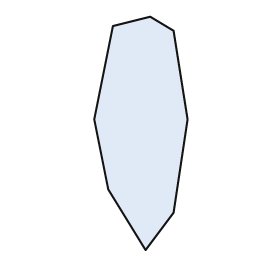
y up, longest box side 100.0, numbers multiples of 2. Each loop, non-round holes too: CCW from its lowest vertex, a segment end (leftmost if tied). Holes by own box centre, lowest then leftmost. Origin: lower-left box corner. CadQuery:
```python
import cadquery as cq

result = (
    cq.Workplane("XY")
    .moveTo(22.0, 0.0)
    .lineTo(34.0, 16.0)
    .lineTo(40.0, 56.0)
    .lineTo(34.0, 94.0)
    .lineTo(24.0, 100.0)
    .lineTo(8.0, 96.0)
    .lineTo(0.0, 56.0)
    .lineTo(6.0, 26.0)
    .close()
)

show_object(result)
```